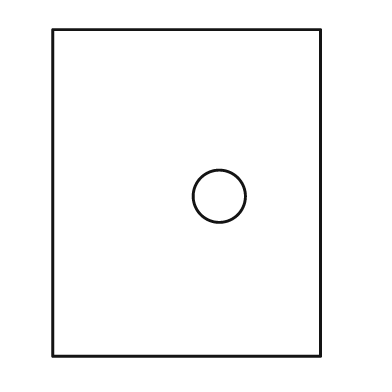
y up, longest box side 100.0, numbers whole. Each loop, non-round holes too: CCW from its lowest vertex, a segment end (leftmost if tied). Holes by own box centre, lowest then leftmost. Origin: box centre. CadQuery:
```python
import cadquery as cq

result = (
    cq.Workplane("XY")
    .moveTo(-41.0, -50.0)
    .lineTo(41.0, -50.0)
    .lineTo(41.0, 50.0)
    .lineTo(-41.0, 50.0)
    .close()
    .moveTo(10.0, -1.0)
    .circle(8.0)
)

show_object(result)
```